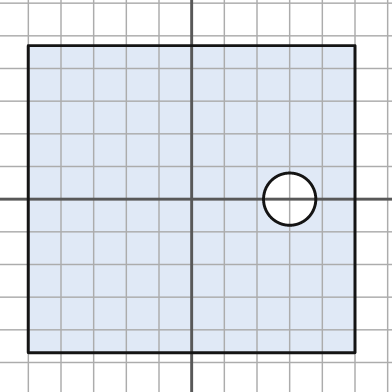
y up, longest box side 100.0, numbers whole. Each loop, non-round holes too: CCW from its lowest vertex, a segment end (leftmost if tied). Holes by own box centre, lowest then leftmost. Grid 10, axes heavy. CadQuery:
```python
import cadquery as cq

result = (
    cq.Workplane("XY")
    .moveTo(-50.0, -47.0)
    .lineTo(50.0, -47.0)
    .lineTo(50.0, 47.0)
    .lineTo(-50.0, 47.0)
    .close()
    .moveTo(30.0, 0.0)
    .circle(8.0)
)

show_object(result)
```